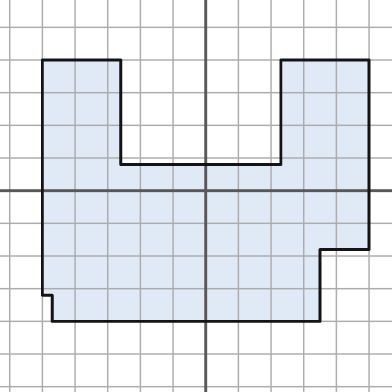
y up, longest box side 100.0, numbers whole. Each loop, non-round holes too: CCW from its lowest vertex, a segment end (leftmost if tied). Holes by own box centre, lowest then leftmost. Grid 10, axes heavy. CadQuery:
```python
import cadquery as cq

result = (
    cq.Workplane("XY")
    .moveTo(-47.0, -40.0)
    .lineTo(35.0, -40.0)
    .lineTo(35.0, -18.0)
    .lineTo(50.0, -18.0)
    .lineTo(50.0, 40.0)
    .lineTo(23.0, 40.0)
    .lineTo(23.0, 8.0)
    .lineTo(-26.0, 8.0)
    .lineTo(-26.0, 40.0)
    .lineTo(-50.0, 40.0)
    .lineTo(-50.0, -32.0)
    .lineTo(-47.0, -32.0)
    .close()
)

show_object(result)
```